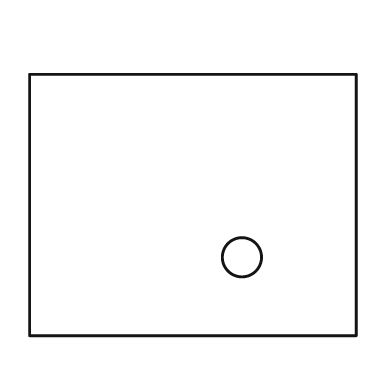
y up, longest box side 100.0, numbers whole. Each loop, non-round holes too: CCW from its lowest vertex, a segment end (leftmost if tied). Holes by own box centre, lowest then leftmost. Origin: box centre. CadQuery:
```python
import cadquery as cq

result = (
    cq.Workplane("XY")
    .moveTo(-50.0, -40.0)
    .lineTo(50.0, -40.0)
    .lineTo(50.0, 40.0)
    .lineTo(-50.0, 40.0)
    .close()
    .moveTo(15.0, -16.0)
    .circle(6.0)
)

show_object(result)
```